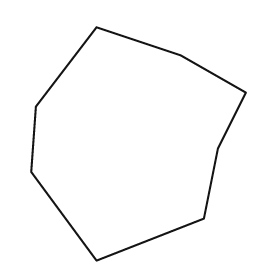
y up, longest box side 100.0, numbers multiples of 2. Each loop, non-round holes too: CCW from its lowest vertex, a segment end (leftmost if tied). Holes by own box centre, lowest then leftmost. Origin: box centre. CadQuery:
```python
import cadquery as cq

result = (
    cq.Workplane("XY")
    .moveTo(-18.0, -50.0)
    .lineTo(28.0, -32.0)
    .lineTo(34.0, -2.0)
    .lineTo(46.0, 22.0)
    .lineTo(18.0, 38.0)
    .lineTo(-18.0, 50.0)
    .lineTo(-44.0, 16.0)
    .lineTo(-46.0, -12.0)
    .close()
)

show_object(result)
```